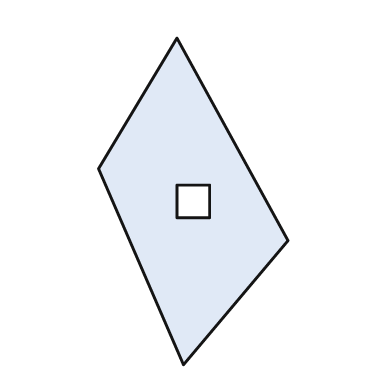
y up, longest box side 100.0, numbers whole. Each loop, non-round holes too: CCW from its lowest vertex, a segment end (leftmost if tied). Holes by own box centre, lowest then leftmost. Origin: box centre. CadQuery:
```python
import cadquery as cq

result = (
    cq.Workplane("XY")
    .moveTo(-3.0, -50.0)
    .lineTo(29.0, -12.0)
    .lineTo(-5.0, 50.0)
    .lineTo(-29.0, 10.0)
    .close()
    .moveTo(-5.0, -5.0)
    .lineTo(5.0, -5.0)
    .lineTo(5.0, 5.0)
    .lineTo(-5.0, 5.0)
    .close()
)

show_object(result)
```